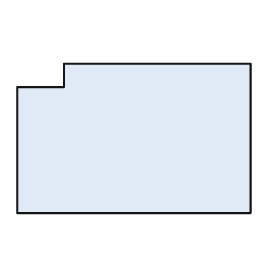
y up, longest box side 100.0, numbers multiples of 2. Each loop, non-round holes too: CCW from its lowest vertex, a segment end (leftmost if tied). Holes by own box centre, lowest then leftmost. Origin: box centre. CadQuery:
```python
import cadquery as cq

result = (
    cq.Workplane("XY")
    .moveTo(-50.0, -32.0)
    .lineTo(50.0, -32.0)
    .lineTo(50.0, 32.0)
    .lineTo(-30.0, 32.0)
    .lineTo(-30.0, 22.0)
    .lineTo(-50.0, 22.0)
    .close()
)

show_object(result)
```